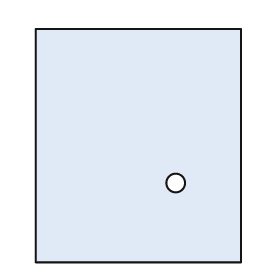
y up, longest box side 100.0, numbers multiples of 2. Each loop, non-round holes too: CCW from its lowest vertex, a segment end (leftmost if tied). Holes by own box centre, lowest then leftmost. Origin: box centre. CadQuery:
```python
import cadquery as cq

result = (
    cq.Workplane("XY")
    .moveTo(-44.0, -50.0)
    .lineTo(44.0, -50.0)
    .lineTo(44.0, 50.0)
    .lineTo(-44.0, 50.0)
    .close()
    .moveTo(16.0, -16.0)
    .circle(4.0)
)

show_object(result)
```